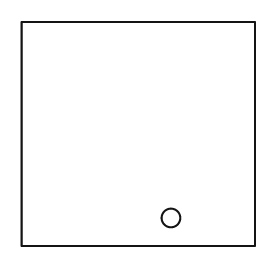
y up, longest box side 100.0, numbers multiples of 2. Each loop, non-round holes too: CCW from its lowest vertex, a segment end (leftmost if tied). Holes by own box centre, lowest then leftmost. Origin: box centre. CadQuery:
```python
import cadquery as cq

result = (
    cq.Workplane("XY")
    .moveTo(-50.0, -48.0)
    .lineTo(50.0, -48.0)
    .lineTo(50.0, 48.0)
    .lineTo(-50.0, 48.0)
    .close()
    .moveTo(14.0, -36.0)
    .circle(4.0)
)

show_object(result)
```